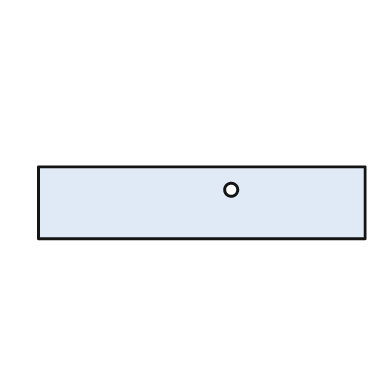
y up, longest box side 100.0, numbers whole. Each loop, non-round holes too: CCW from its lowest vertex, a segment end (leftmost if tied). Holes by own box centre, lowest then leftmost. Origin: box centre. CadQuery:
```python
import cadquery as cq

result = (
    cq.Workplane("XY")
    .moveTo(-50.0, -11.0)
    .lineTo(50.0, -11.0)
    .lineTo(50.0, 11.0)
    .lineTo(-50.0, 11.0)
    .close()
    .moveTo(9.0, 4.0)
    .circle(2.0)
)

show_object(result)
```